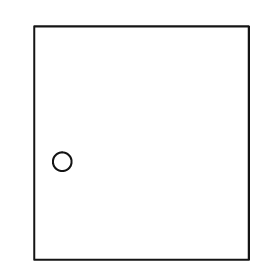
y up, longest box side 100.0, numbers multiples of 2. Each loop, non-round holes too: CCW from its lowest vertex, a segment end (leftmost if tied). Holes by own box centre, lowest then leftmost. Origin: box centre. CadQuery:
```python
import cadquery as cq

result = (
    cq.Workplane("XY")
    .moveTo(-46.0, -50.0)
    .lineTo(46.0, -50.0)
    .lineTo(46.0, 50.0)
    .lineTo(-46.0, 50.0)
    .close()
    .moveTo(-34.0, -8.0)
    .circle(4.0)
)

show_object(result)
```